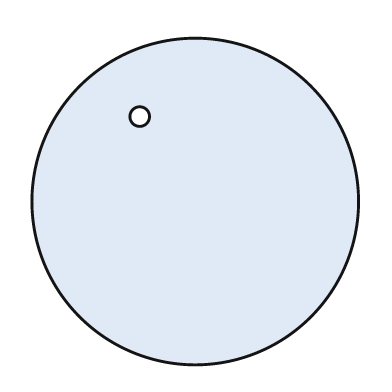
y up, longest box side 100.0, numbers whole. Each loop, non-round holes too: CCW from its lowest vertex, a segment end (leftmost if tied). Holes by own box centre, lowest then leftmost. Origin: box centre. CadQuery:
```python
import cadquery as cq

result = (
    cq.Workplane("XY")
    .moveTo(0.0, 0.0)
    .circle(50.0)
    .moveTo(-17.0, 26.0)
    .circle(3.0)
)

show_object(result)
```